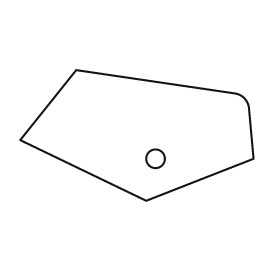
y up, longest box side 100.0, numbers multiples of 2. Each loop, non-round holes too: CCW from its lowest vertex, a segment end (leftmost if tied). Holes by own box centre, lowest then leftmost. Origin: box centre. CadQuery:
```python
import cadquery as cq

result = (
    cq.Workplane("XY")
    .moveTo(4.0, -28.0)
    .lineTo(50.0, -10.0)
    .lineTo(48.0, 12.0)
    .threePointArc((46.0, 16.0), (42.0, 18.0))
    .lineTo(-26.0, 28.0)
    .lineTo(-50.0, -2.0)
    .close()
    .moveTo(8.0, -10.0)
    .circle(4.0)
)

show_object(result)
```